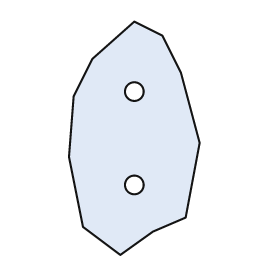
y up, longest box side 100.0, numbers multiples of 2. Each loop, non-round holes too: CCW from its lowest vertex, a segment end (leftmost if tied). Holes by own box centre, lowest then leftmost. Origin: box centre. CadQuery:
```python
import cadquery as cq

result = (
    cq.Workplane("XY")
    .moveTo(-6.0, -50.0)
    .lineTo(8.0, -40.0)
    .lineTo(22.0, -34.0)
    .lineTo(28.0, -2.0)
    .lineTo(20.0, 28.0)
    .lineTo(12.0, 44.0)
    .lineTo(0.0, 50.0)
    .lineTo(-18.0, 34.0)
    .lineTo(-26.0, 18.0)
    .lineTo(-28.0, -8.0)
    .lineTo(-22.0, -38.0)
    .close()
    .moveTo(0.0, -20.0)
    .circle(4.0)
    .moveTo(0.0, 20.0)
    .circle(4.0)
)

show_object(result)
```